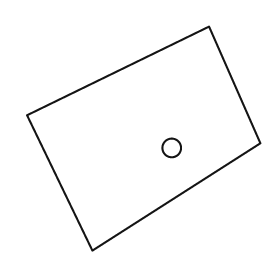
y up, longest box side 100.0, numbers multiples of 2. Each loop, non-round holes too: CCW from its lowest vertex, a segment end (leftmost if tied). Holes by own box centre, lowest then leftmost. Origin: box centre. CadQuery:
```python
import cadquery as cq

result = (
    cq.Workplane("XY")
    .moveTo(-22.0, -48.0)
    .lineTo(50.0, -2.0)
    .lineTo(28.0, 48.0)
    .lineTo(-50.0, 10.0)
    .close()
    .moveTo(12.0, -4.0)
    .circle(4.0)
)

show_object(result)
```